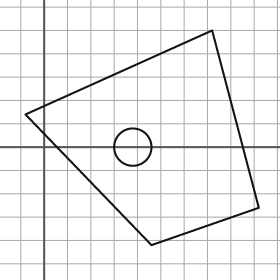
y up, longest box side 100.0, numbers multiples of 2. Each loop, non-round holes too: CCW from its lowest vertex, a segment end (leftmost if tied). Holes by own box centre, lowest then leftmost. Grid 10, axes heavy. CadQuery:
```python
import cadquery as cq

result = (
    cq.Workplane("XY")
    .moveTo(46.0, -42.0)
    .lineTo(92.0, -26.0)
    .lineTo(72.0, 50.0)
    .lineTo(-8.0, 14.0)
    .close()
    .moveTo(38.0, 0.0)
    .circle(8.0)
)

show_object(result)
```